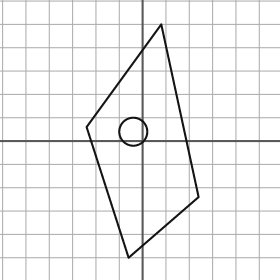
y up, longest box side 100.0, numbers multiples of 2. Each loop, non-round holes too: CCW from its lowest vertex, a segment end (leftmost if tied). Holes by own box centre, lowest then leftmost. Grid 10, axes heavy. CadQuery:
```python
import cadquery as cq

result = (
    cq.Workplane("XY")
    .moveTo(-6.0, -50.0)
    .lineTo(24.0, -24.0)
    .lineTo(8.0, 50.0)
    .lineTo(-24.0, 6.0)
    .close()
    .moveTo(-4.0, 4.0)
    .circle(6.0)
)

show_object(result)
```